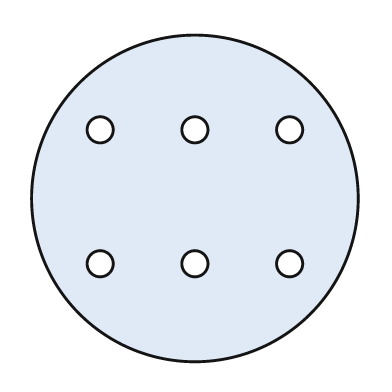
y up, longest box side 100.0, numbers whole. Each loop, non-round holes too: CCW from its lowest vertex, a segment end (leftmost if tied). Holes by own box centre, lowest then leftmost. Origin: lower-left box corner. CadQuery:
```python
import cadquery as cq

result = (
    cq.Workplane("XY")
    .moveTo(50.0, 50.0)
    .circle(50.0)
    .moveTo(21.0, 30.0)
    .circle(4.0)
    .moveTo(50.0, 30.0)
    .circle(4.0)
    .moveTo(79.0, 30.0)
    .circle(4.0)
    .moveTo(21.0, 71.0)
    .circle(4.0)
    .moveTo(50.0, 71.0)
    .circle(4.0)
    .moveTo(79.0, 71.0)
    .circle(4.0)
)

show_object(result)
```